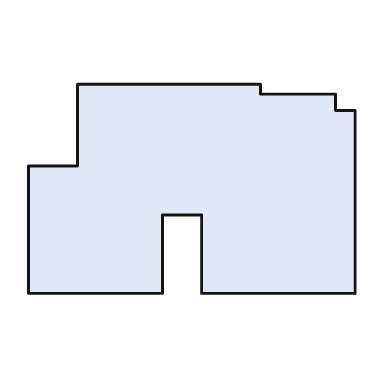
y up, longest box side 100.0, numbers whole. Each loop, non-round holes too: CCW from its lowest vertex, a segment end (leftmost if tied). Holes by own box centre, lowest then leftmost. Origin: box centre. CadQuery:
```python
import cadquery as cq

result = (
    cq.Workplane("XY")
    .moveTo(-50.0, -32.0)
    .lineTo(-9.0, -32.0)
    .lineTo(-9.0, -8.0)
    .lineTo(3.0, -8.0)
    .lineTo(3.0, -32.0)
    .lineTo(50.0, -32.0)
    .lineTo(50.0, 24.0)
    .lineTo(44.0, 24.0)
    .lineTo(44.0, 29.0)
    .lineTo(21.0, 29.0)
    .lineTo(21.0, 32.0)
    .lineTo(-35.0, 32.0)
    .lineTo(-35.0, 7.0)
    .lineTo(-50.0, 7.0)
    .close()
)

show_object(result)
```